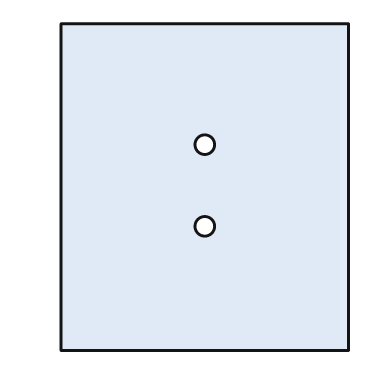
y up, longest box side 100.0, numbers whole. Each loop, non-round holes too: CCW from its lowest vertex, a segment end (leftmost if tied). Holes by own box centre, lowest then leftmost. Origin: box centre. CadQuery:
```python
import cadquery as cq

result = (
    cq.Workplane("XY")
    .moveTo(-44.0, -50.0)
    .lineTo(44.0, -50.0)
    .lineTo(44.0, 50.0)
    .lineTo(-44.0, 50.0)
    .close()
    .moveTo(0.0, -12.0)
    .circle(3.0)
    .moveTo(0.0, 13.0)
    .circle(3.0)
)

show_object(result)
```